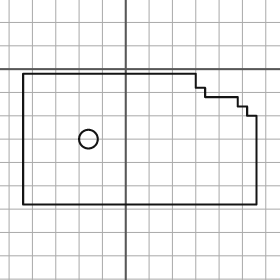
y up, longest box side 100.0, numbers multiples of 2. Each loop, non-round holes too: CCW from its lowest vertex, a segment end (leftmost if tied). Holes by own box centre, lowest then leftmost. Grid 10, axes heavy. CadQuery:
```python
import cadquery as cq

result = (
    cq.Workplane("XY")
    .moveTo(-44.0, -58.0)
    .lineTo(56.0, -58.0)
    .lineTo(56.0, -20.0)
    .lineTo(52.0, -20.0)
    .lineTo(52.0, -16.0)
    .lineTo(48.0, -16.0)
    .lineTo(48.0, -12.0)
    .lineTo(34.0, -12.0)
    .lineTo(34.0, -8.0)
    .lineTo(30.0, -8.0)
    .lineTo(30.0, -2.0)
    .lineTo(-44.0, -2.0)
    .close()
    .moveTo(-16.0, -30.0)
    .circle(4.0)
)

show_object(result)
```